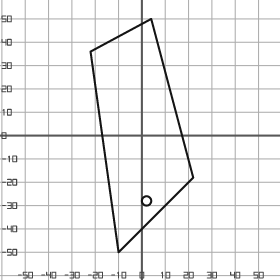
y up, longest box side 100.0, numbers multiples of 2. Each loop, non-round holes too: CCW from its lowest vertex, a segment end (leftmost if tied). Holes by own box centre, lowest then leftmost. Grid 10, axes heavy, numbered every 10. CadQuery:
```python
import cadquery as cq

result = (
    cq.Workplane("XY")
    .moveTo(-10.0, -50.0)
    .lineTo(22.0, -18.0)
    .lineTo(4.0, 50.0)
    .lineTo(-22.0, 36.0)
    .close()
    .moveTo(2.0, -28.0)
    .circle(2.0)
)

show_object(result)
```